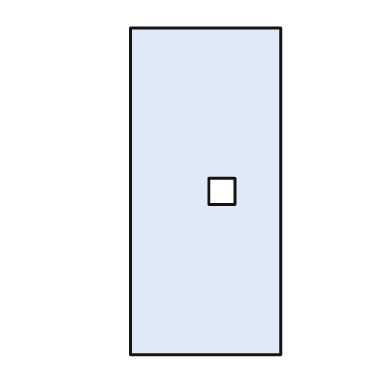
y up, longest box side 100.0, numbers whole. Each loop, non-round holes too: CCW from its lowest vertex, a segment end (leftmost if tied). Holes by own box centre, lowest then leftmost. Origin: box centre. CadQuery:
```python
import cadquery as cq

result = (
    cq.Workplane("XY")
    .moveTo(-23.0, -50.0)
    .lineTo(23.0, -50.0)
    .lineTo(23.0, 50.0)
    .lineTo(-23.0, 50.0)
    .close()
    .moveTo(1.0, -4.0)
    .lineTo(9.0, -4.0)
    .lineTo(9.0, 4.0)
    .lineTo(1.0, 4.0)
    .close()
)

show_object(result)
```